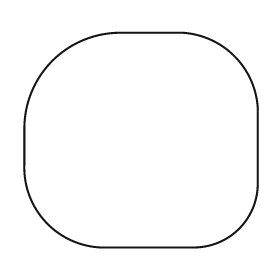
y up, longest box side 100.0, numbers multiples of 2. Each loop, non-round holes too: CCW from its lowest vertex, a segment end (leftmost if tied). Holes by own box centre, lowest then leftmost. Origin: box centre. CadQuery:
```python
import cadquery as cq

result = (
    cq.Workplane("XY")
    .moveTo(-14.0, -46.0)
    .lineTo(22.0, -46.0)
    .threePointArc((42.0, -38.0), (50.0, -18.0))
    .lineTo(50.0, 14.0)
    .threePointArc((40.0, 36.0), (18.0, 46.0))
    .lineTo(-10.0, 46.0)
    .threePointArc((-38.0, 34.0), (-50.0, 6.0))
    .lineTo(-50.0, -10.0)
    .threePointArc((-40.0, -36.0), (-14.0, -46.0))
    .close()
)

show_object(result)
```